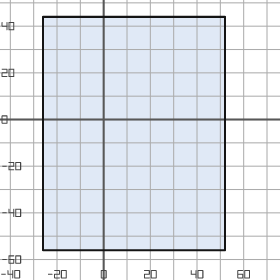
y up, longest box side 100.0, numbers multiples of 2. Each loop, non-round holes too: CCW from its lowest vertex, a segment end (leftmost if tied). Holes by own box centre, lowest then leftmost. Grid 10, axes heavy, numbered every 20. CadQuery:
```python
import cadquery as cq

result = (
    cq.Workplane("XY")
    .moveTo(-26.0, -56.0)
    .lineTo(52.0, -56.0)
    .lineTo(52.0, 44.0)
    .lineTo(-26.0, 44.0)
    .close()
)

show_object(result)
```